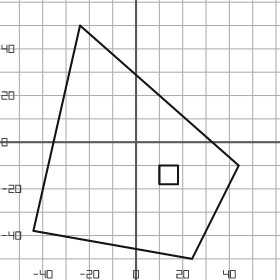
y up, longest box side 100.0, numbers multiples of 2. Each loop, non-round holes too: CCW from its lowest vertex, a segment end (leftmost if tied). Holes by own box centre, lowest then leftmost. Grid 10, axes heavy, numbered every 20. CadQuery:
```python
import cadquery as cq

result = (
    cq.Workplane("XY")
    .moveTo(24.0, -50.0)
    .lineTo(44.0, -10.0)
    .lineTo(-24.0, 50.0)
    .lineTo(-44.0, -38.0)
    .close()
    .moveTo(10.0, -18.0)
    .lineTo(18.0, -18.0)
    .lineTo(18.0, -10.0)
    .lineTo(10.0, -10.0)
    .close()
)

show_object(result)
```